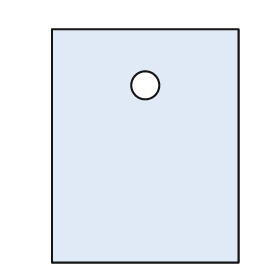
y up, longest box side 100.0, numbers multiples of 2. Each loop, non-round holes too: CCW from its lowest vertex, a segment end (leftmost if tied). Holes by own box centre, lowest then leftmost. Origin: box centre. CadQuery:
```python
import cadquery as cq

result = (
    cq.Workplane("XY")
    .moveTo(-40.0, -50.0)
    .lineTo(40.0, -50.0)
    .lineTo(40.0, 50.0)
    .lineTo(-40.0, 50.0)
    .close()
    .moveTo(0.0, 26.0)
    .circle(6.0)
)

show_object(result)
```